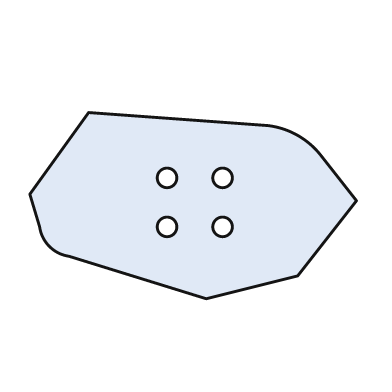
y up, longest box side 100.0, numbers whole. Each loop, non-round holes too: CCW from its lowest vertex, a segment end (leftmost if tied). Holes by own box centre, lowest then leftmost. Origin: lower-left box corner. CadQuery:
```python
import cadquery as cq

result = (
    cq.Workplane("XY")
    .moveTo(54.0, 0.0)
    .lineTo(82.0, 7.0)
    .lineTo(100.0, 30.0)
    .lineTo(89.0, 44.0)
    .threePointArc((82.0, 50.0), (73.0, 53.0))
    .lineTo(18.0, 57.0)
    .lineTo(0.0, 32.0)
    .lineTo(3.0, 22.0)
    .threePointArc((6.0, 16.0), (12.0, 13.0))
    .close()
    .moveTo(42.0, 22.0)
    .circle(3.0)
    .moveTo(59.0, 22.0)
    .circle(3.0)
    .moveTo(42.0, 37.0)
    .circle(3.0)
    .moveTo(59.0, 37.0)
    .circle(3.0)
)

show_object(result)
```